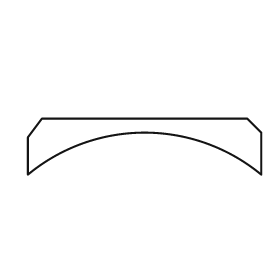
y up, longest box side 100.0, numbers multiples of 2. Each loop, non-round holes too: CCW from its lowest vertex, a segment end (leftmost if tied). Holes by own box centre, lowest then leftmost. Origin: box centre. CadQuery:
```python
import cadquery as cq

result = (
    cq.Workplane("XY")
    .moveTo(-50.0, -12.0)
    .threePointArc((0.0, 6.0), (50.0, -12.0))
    .lineTo(50.0, 6.0)
    .lineTo(44.0, 12.0)
    .lineTo(-44.0, 12.0)
    .lineTo(-50.0, 4.0)
    .close()
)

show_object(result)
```